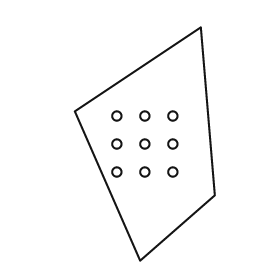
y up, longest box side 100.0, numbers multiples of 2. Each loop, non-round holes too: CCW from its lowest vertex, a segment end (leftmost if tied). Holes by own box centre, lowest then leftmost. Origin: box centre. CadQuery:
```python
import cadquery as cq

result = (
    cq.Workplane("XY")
    .moveTo(-2.0, -50.0)
    .lineTo(30.0, -22.0)
    .lineTo(24.0, 50.0)
    .lineTo(-30.0, 14.0)
    .close()
    .moveTo(-12.0, -12.0)
    .circle(2.0)
    .moveTo(0.0, -12.0)
    .circle(2.0)
    .moveTo(12.0, -12.0)
    .circle(2.0)
    .moveTo(-12.0, 0.0)
    .circle(2.0)
    .moveTo(0.0, 0.0)
    .circle(2.0)
    .moveTo(12.0, 0.0)
    .circle(2.0)
    .moveTo(-12.0, 12.0)
    .circle(2.0)
    .moveTo(0.0, 12.0)
    .circle(2.0)
    .moveTo(12.0, 12.0)
    .circle(2.0)
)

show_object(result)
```